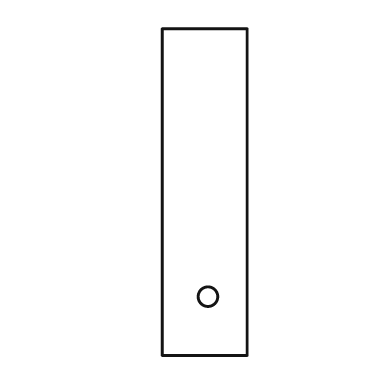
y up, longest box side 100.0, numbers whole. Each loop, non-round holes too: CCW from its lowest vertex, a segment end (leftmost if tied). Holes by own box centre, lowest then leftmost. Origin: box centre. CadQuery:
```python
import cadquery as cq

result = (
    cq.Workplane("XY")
    .moveTo(-13.0, -50.0)
    .lineTo(13.0, -50.0)
    .lineTo(13.0, 50.0)
    .lineTo(-13.0, 50.0)
    .close()
    .moveTo(1.0, -32.0)
    .circle(3.0)
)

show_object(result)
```